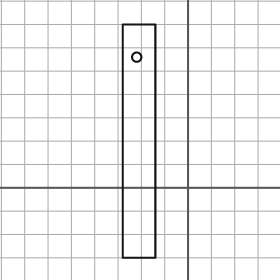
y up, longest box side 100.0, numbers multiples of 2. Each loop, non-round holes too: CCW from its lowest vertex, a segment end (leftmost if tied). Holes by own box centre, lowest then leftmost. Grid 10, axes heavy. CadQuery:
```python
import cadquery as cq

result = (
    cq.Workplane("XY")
    .moveTo(-28.0, -30.0)
    .lineTo(-14.0, -30.0)
    .lineTo(-14.0, 70.0)
    .lineTo(-28.0, 70.0)
    .close()
    .moveTo(-22.0, 56.0)
    .circle(2.0)
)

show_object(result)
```